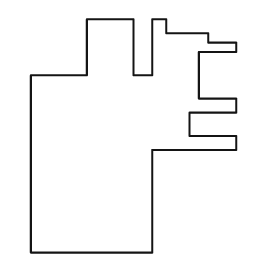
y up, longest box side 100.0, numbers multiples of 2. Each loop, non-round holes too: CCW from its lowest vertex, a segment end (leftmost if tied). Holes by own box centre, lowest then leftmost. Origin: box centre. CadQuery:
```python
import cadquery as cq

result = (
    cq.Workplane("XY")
    .moveTo(-44.0, -50.0)
    .lineTo(8.0, -50.0)
    .lineTo(8.0, -6.0)
    .lineTo(44.0, -6.0)
    .lineTo(44.0, 0.0)
    .lineTo(24.0, 0.0)
    .lineTo(24.0, 10.0)
    .lineTo(44.0, 10.0)
    .lineTo(44.0, 16.0)
    .lineTo(28.0, 16.0)
    .lineTo(28.0, 36.0)
    .lineTo(44.0, 36.0)
    .lineTo(44.0, 40.0)
    .lineTo(32.0, 40.0)
    .lineTo(32.0, 44.0)
    .lineTo(14.0, 44.0)
    .lineTo(14.0, 50.0)
    .lineTo(8.0, 50.0)
    .lineTo(8.0, 26.0)
    .lineTo(0.0, 26.0)
    .lineTo(0.0, 50.0)
    .lineTo(-20.0, 50.0)
    .lineTo(-20.0, 26.0)
    .lineTo(-44.0, 26.0)
    .close()
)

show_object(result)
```